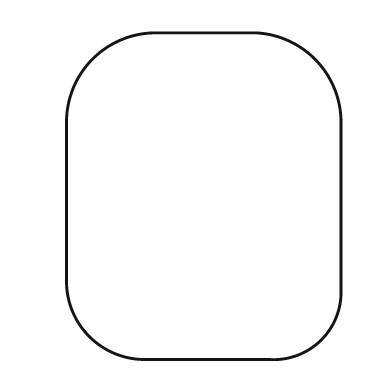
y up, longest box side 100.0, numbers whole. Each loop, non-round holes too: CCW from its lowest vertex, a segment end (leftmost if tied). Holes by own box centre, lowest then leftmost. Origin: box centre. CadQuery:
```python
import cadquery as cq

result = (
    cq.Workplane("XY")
    .moveTo(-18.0, -50.0)
    .lineTo(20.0, -50.0)
    .threePointArc((36.0, -44.0), (42.0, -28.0))
    .lineTo(42.0, 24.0)
    .threePointArc((34.0, 42.0), (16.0, 50.0))
    .lineTo(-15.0, 50.0)
    .threePointArc((-34.0, 42.0), (-42.0, 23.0))
    .lineTo(-42.0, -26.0)
    .threePointArc((-35.0, -43.0), (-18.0, -50.0))
    .close()
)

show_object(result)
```